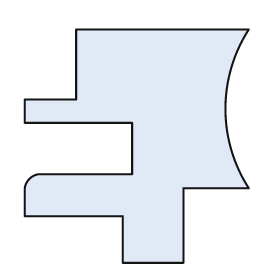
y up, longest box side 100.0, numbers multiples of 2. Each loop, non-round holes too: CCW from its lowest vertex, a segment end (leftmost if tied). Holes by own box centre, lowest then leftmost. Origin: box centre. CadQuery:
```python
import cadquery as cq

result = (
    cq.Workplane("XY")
    .moveTo(-6.0, -50.0)
    .lineTo(20.0, -50.0)
    .lineTo(20.0, -18.0)
    .lineTo(48.0, -18.0)
    .threePointArc((38.0, 16.0), (48.0, 50.0))
    .lineTo(-26.0, 50.0)
    .lineTo(-26.0, 20.0)
    .lineTo(-48.0, 20.0)
    .lineTo(-48.0, 10.0)
    .lineTo(-2.0, 10.0)
    .lineTo(-2.0, -12.0)
    .lineTo(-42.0, -12.0)
    .threePointArc((-46.0, -14.0), (-48.0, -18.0))
    .lineTo(-48.0, -30.0)
    .lineTo(-6.0, -30.0)
    .close()
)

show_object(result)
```